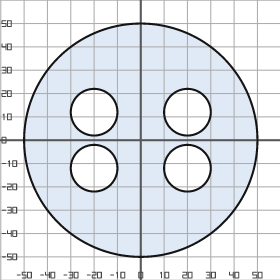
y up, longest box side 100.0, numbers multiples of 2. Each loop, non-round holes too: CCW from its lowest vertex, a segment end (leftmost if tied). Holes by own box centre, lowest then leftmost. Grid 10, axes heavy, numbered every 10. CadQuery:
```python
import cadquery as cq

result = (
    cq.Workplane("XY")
    .moveTo(0.0, 0.0)
    .circle(50.0)
    .moveTo(-20.0, -12.0)
    .circle(10.0)
    .moveTo(20.0, -12.0)
    .circle(10.0)
    .moveTo(-20.0, 12.0)
    .circle(10.0)
    .moveTo(20.0, 12.0)
    .circle(10.0)
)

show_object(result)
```